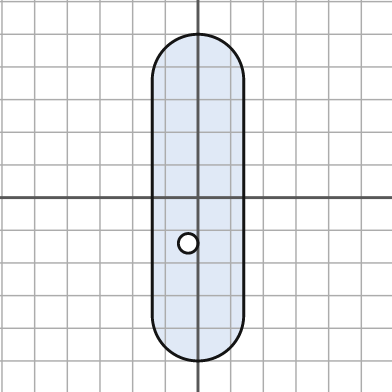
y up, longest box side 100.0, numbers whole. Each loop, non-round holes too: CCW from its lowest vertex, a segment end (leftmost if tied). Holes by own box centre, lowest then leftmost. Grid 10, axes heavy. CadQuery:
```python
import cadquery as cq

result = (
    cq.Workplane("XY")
    .moveTo(-14.0, -36.0)
    .threePointArc((0.0, -50.0), (14.0, -36.0))
    .lineTo(14.0, 36.0)
    .threePointArc((0.0, 50.0), (-14.0, 36.0))
    .close()
    .moveTo(-3.0, -14.0)
    .circle(3.0)
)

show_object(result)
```